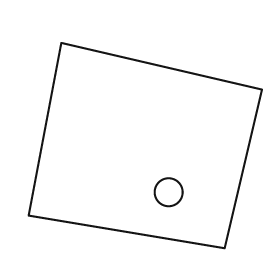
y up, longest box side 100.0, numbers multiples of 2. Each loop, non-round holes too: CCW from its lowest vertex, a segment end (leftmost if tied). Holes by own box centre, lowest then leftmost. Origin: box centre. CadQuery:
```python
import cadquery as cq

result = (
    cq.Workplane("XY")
    .moveTo(34.0, -44.0)
    .lineTo(50.0, 24.0)
    .lineTo(-36.0, 44.0)
    .lineTo(-50.0, -30.0)
    .close()
    .moveTo(10.0, -20.0)
    .circle(6.0)
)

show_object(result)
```